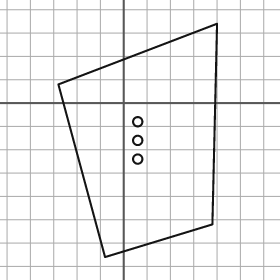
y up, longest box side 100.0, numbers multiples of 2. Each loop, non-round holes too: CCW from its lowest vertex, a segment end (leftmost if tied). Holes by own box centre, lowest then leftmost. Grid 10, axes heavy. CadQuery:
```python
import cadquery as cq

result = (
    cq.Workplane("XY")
    .moveTo(-8.0, -66.0)
    .lineTo(38.0, -52.0)
    .lineTo(40.0, 34.0)
    .lineTo(-28.0, 8.0)
    .close()
    .moveTo(6.0, -24.0)
    .circle(2.0)
    .moveTo(6.0, -16.0)
    .circle(2.0)
    .moveTo(6.0, -8.0)
    .circle(2.0)
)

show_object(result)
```